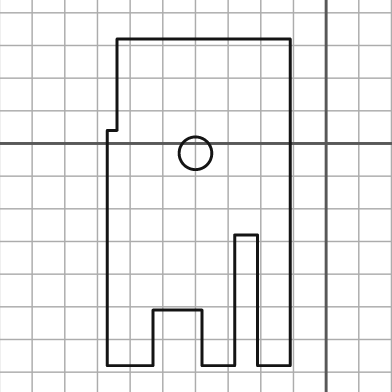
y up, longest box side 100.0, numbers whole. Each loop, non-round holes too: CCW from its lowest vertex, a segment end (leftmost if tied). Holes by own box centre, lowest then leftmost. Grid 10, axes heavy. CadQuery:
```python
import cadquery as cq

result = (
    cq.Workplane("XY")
    .moveTo(-67.0, -68.0)
    .lineTo(-53.0, -68.0)
    .lineTo(-53.0, -51.0)
    .lineTo(-38.0, -51.0)
    .lineTo(-38.0, -68.0)
    .lineTo(-28.0, -68.0)
    .lineTo(-28.0, -28.0)
    .lineTo(-21.0, -28.0)
    .lineTo(-21.0, -68.0)
    .lineTo(-11.0, -68.0)
    .lineTo(-11.0, 32.0)
    .lineTo(-64.0, 32.0)
    .lineTo(-64.0, 4.0)
    .lineTo(-67.0, 4.0)
    .close()
    .moveTo(-40.0, -3.0)
    .circle(5.0)
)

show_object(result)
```